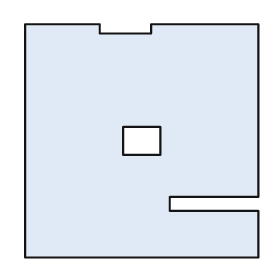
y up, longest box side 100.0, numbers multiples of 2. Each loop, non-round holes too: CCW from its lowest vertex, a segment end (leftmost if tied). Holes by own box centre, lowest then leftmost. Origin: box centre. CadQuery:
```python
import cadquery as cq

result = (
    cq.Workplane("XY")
    .moveTo(-50.0, -50.0)
    .lineTo(50.0, -50.0)
    .lineTo(50.0, -30.0)
    .lineTo(12.0, -30.0)
    .lineTo(12.0, -24.0)
    .lineTo(50.0, -24.0)
    .lineTo(50.0, 50.0)
    .lineTo(4.0, 50.0)
    .lineTo(4.0, 46.0)
    .lineTo(-18.0, 46.0)
    .lineTo(-18.0, 50.0)
    .lineTo(-50.0, 50.0)
    .close()
    .moveTo(-8.0, -6.0)
    .lineTo(8.0, -6.0)
    .lineTo(8.0, 6.0)
    .lineTo(-8.0, 6.0)
    .close()
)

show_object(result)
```